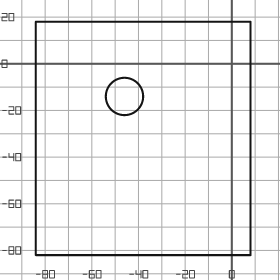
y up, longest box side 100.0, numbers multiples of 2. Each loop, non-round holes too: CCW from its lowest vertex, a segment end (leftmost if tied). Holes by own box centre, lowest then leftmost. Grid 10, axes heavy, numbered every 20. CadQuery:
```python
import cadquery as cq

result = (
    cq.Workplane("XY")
    .moveTo(-84.0, -82.0)
    .lineTo(8.0, -82.0)
    .lineTo(8.0, 18.0)
    .lineTo(-84.0, 18.0)
    .close()
    .moveTo(-46.0, -14.0)
    .circle(8.0)
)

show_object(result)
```